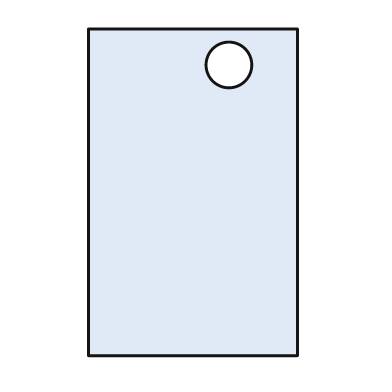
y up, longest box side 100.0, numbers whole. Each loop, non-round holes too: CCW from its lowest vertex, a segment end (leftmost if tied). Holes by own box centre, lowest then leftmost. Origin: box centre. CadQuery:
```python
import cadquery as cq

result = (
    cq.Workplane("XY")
    .moveTo(-32.0, -50.0)
    .lineTo(32.0, -50.0)
    .lineTo(32.0, 50.0)
    .lineTo(-32.0, 50.0)
    .close()
    .moveTo(11.0, 39.0)
    .circle(7.0)
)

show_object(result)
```